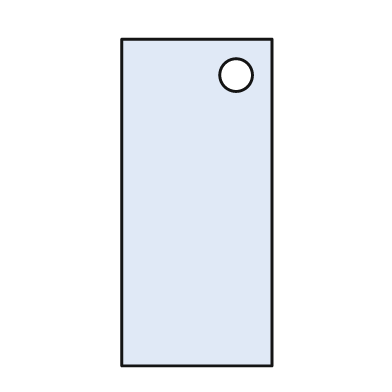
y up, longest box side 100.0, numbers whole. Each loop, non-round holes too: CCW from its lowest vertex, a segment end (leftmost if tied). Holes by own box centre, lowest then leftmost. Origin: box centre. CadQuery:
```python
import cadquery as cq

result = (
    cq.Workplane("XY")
    .moveTo(-23.0, -50.0)
    .lineTo(23.0, -50.0)
    .lineTo(23.0, 50.0)
    .lineTo(-23.0, 50.0)
    .close()
    .moveTo(12.0, 39.0)
    .circle(5.0)
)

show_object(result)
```